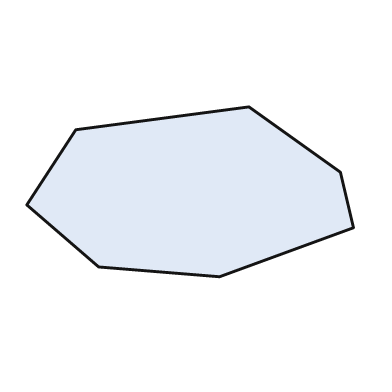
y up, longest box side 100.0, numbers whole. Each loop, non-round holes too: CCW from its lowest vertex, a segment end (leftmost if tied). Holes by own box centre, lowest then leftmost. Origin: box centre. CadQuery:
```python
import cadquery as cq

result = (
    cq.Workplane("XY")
    .moveTo(9.0, -26.0)
    .lineTo(50.0, -11.0)
    .lineTo(46.0, 6.0)
    .lineTo(18.0, 26.0)
    .lineTo(-35.0, 19.0)
    .lineTo(-50.0, -4.0)
    .lineTo(-28.0, -23.0)
    .close()
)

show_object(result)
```